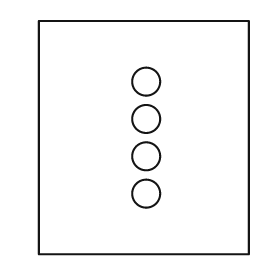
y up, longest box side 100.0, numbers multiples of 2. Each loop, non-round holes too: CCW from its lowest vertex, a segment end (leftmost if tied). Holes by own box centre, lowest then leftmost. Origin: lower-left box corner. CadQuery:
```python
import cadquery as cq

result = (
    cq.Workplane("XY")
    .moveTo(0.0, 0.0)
    .lineTo(90.0, 0.0)
    .lineTo(90.0, 100.0)
    .lineTo(0.0, 100.0)
    .close()
    .moveTo(46.0, 26.0)
    .circle(6.0)
    .moveTo(46.0, 42.0)
    .circle(6.0)
    .moveTo(46.0, 58.0)
    .circle(6.0)
    .moveTo(46.0, 74.0)
    .circle(6.0)
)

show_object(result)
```